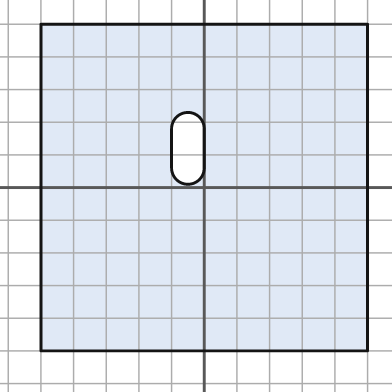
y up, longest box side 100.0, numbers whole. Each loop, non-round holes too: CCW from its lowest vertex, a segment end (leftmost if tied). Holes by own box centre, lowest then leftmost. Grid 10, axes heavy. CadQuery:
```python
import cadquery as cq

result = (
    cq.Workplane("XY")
    .moveTo(-50.0, -50.0)
    .lineTo(50.0, -50.0)
    .lineTo(50.0, 50.0)
    .lineTo(-50.0, 50.0)
    .close()
    .moveTo(-10.0, 6.0)
    .threePointArc((-5.0, 1.0), (0.0, 6.0))
    .lineTo(0.0, 18.0)
    .threePointArc((-5.0, 23.0), (-10.0, 18.0))
    .close()
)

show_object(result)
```